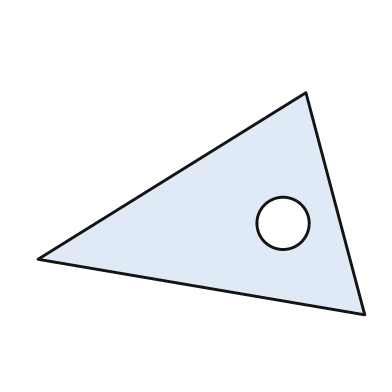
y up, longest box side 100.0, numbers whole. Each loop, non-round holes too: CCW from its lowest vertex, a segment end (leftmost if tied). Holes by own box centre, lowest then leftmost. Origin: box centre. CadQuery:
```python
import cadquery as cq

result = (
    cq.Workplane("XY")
    .moveTo(50.0, -34.0)
    .lineTo(32.0, 34.0)
    .lineTo(-50.0, -17.0)
    .close()
    .moveTo(25.0, -6.0)
    .circle(8.0)
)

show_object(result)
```